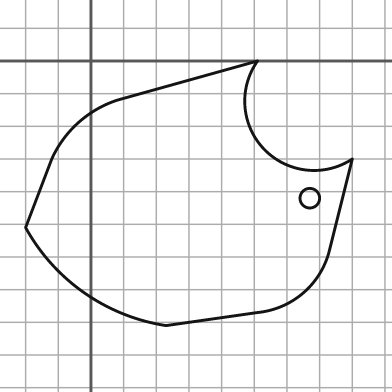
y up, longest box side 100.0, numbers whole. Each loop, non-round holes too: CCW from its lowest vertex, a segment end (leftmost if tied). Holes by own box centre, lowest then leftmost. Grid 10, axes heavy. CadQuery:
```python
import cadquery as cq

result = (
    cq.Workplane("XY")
    .moveTo(23.0, -81.0)
    .lineTo(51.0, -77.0)
    .threePointArc((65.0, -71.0), (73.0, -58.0))
    .lineTo(80.0, -30.0)
    .threePointArc((53.0, -27.0), (51.0, 0.0))
    .lineTo(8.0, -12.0)
    .threePointArc((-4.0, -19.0), (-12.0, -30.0))
    .lineTo(-20.0, -51.0)
    .threePointArc((-2.0, -71.0), (23.0, -81.0))
    .close()
    .moveTo(67.0, -42.0)
    .circle(3.0)
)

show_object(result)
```